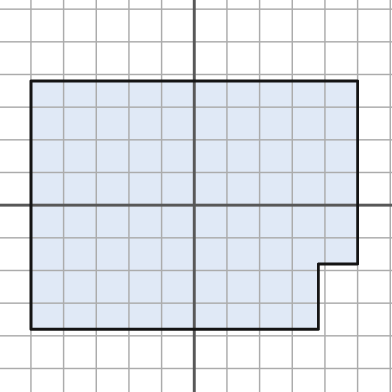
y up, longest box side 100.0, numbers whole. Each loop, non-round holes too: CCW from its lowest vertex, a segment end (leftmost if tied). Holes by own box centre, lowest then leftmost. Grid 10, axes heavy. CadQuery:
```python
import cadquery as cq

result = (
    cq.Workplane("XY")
    .moveTo(-50.0, -38.0)
    .lineTo(38.0, -38.0)
    .lineTo(38.0, -18.0)
    .lineTo(50.0, -18.0)
    .lineTo(50.0, 38.0)
    .lineTo(-50.0, 38.0)
    .close()
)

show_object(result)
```